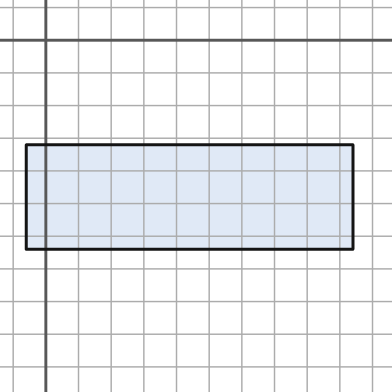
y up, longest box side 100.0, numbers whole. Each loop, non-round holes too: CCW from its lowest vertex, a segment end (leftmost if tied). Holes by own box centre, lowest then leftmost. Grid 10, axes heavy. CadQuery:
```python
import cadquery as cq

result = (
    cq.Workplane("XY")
    .moveTo(-6.0, -64.0)
    .lineTo(94.0, -64.0)
    .lineTo(94.0, -32.0)
    .lineTo(-6.0, -32.0)
    .close()
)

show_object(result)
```